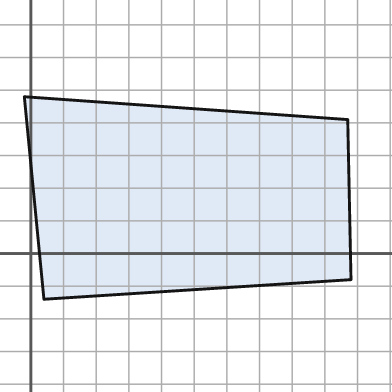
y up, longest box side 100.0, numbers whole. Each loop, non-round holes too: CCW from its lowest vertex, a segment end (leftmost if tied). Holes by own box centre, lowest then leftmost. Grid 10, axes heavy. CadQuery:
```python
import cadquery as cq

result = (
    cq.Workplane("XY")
    .moveTo(4.0, -14.0)
    .lineTo(98.0, -8.0)
    .lineTo(97.0, 41.0)
    .lineTo(-2.0, 48.0)
    .close()
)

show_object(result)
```